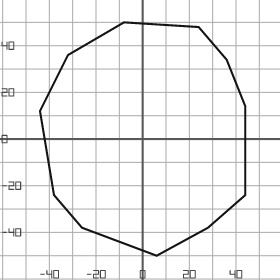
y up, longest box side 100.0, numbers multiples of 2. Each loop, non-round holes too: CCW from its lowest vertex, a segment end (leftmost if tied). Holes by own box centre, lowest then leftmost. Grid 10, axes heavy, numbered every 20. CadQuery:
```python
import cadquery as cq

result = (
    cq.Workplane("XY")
    .moveTo(6.0, -50.0)
    .lineTo(28.0, -38.0)
    .lineTo(44.0, -24.0)
    .lineTo(44.0, 14.0)
    .lineTo(36.0, 34.0)
    .lineTo(24.0, 48.0)
    .lineTo(-8.0, 50.0)
    .lineTo(-32.0, 36.0)
    .lineTo(-44.0, 12.0)
    .lineTo(-38.0, -24.0)
    .lineTo(-26.0, -38.0)
    .close()
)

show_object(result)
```